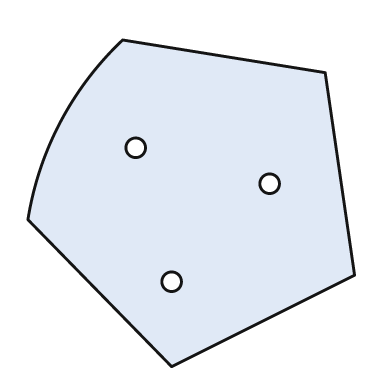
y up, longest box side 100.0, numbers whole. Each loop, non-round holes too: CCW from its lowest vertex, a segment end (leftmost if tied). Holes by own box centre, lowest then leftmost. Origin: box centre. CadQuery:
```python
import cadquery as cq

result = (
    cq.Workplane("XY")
    .moveTo(-6.0, -50.0)
    .lineTo(50.0, -22.0)
    .lineTo(41.0, 40.0)
    .lineTo(-21.0, 50.0)
    .threePointArc((-40.0, 25.0), (-50.0, -5.0))
    .close()
    .moveTo(-6.0, -24.0)
    .circle(3.0)
    .moveTo(24.0, 6.0)
    .circle(3.0)
    .moveTo(-17.0, 17.0)
    .circle(3.0)
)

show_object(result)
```